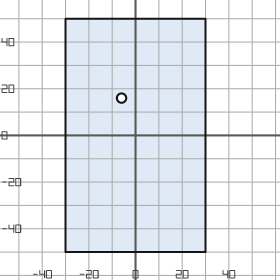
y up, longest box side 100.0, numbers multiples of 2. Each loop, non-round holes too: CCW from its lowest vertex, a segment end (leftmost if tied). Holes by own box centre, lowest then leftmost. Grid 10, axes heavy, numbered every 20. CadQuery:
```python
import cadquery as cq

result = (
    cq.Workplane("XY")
    .moveTo(-30.0, -50.0)
    .lineTo(30.0, -50.0)
    .lineTo(30.0, 50.0)
    .lineTo(-30.0, 50.0)
    .close()
    .moveTo(-6.0, 16.0)
    .circle(2.0)
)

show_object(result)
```